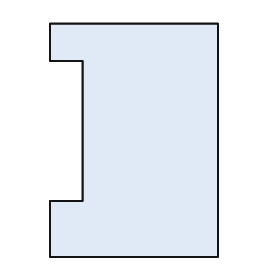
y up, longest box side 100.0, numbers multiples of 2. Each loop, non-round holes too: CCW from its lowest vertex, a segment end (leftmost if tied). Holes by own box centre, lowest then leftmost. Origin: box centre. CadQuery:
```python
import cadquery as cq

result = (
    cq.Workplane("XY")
    .moveTo(-36.0, -50.0)
    .lineTo(36.0, -50.0)
    .lineTo(36.0, 50.0)
    .lineTo(-36.0, 50.0)
    .lineTo(-36.0, 34.0)
    .lineTo(-22.0, 34.0)
    .lineTo(-22.0, -26.0)
    .lineTo(-36.0, -26.0)
    .close()
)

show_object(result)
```